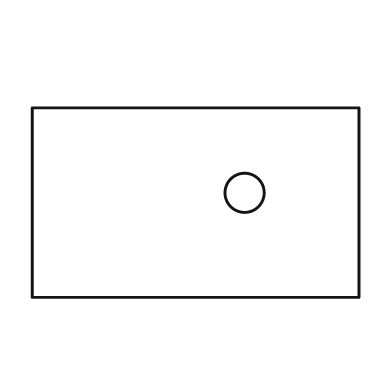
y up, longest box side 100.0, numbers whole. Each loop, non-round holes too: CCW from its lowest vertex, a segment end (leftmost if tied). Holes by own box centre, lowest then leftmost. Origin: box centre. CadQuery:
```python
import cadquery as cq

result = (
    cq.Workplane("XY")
    .moveTo(-50.0, -29.0)
    .lineTo(50.0, -29.0)
    .lineTo(50.0, 29.0)
    .lineTo(-50.0, 29.0)
    .close()
    .moveTo(15.0, 3.0)
    .circle(6.0)
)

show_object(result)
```